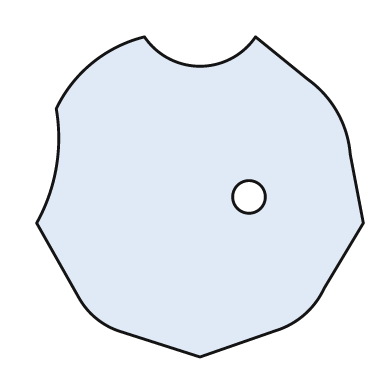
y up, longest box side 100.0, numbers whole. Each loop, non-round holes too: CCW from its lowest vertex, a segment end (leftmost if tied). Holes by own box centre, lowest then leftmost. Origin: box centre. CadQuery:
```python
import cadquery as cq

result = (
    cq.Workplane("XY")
    .moveTo(0.0, -49.0)
    .lineTo(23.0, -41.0)
    .threePointArc((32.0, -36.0), (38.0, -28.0))
    .lineTo(50.0, -8.0)
    .lineTo(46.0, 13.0)
    .threePointArc((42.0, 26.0), (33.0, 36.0))
    .lineTo(17.0, 49.0)
    .threePointArc((0.0, 40.0), (-17.0, 49.0))
    .threePointArc((-33.0, 41.0), (-44.0, 27.0))
    .threePointArc((-44.0, 9.0), (-50.0, -8.0))
    .lineTo(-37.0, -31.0)
    .threePointArc((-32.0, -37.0), (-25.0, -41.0))
    .close()
    .moveTo(15.0, 0.0)
    .circle(5.0)
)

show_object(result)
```